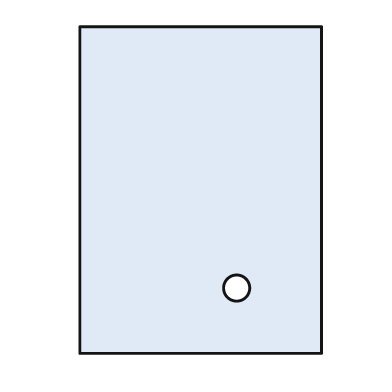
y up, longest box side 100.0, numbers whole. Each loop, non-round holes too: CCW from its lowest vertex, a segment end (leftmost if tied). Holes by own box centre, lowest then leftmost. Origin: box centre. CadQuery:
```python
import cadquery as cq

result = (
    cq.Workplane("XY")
    .moveTo(-37.0, -50.0)
    .lineTo(37.0, -50.0)
    .lineTo(37.0, 50.0)
    .lineTo(-37.0, 50.0)
    .close()
    .moveTo(11.0, -30.0)
    .circle(4.0)
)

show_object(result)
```